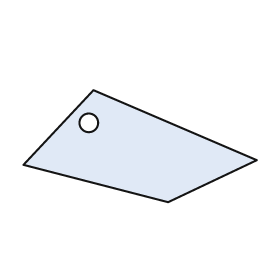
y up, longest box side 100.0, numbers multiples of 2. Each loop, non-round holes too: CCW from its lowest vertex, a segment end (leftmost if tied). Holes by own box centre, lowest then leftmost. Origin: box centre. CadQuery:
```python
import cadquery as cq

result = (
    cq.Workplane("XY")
    .moveTo(12.0, -24.0)
    .lineTo(50.0, -6.0)
    .lineTo(-20.0, 24.0)
    .lineTo(-50.0, -8.0)
    .close()
    .moveTo(-22.0, 10.0)
    .circle(4.0)
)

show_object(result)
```